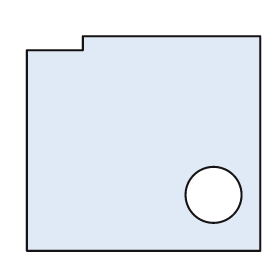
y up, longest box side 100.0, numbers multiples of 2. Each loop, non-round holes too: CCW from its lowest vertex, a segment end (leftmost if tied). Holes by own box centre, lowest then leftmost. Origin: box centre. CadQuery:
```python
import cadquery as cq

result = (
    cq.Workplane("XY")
    .moveTo(-50.0, -46.0)
    .lineTo(50.0, -46.0)
    .lineTo(50.0, 46.0)
    .lineTo(-26.0, 46.0)
    .lineTo(-26.0, 40.0)
    .lineTo(-50.0, 40.0)
    .close()
    .moveTo(30.0, -22.0)
    .circle(12.0)
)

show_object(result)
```